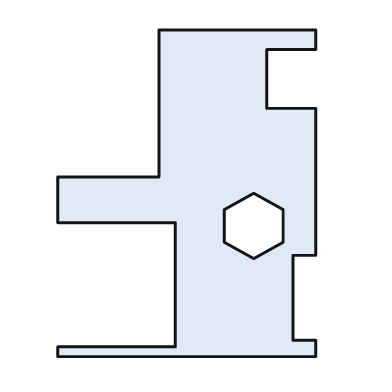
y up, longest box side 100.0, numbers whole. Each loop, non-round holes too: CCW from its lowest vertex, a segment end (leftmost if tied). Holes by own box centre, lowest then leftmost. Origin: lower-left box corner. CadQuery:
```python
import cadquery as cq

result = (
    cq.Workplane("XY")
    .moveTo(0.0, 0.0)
    .lineTo(79.0, 0.0)
    .lineTo(79.0, 5.0)
    .lineTo(72.0, 5.0)
    .lineTo(72.0, 31.0)
    .lineTo(79.0, 31.0)
    .lineTo(79.0, 76.0)
    .lineTo(64.0, 76.0)
    .lineTo(64.0, 94.0)
    .lineTo(79.0, 94.0)
    .lineTo(79.0, 100.0)
    .lineTo(31.0, 100.0)
    .lineTo(31.0, 55.0)
    .lineTo(0.0, 55.0)
    .lineTo(0.0, 41.0)
    .lineTo(36.0, 41.0)
    .lineTo(36.0, 3.0)
    .lineTo(0.0, 3.0)
    .close()
    .moveTo(60.0, 30.0)
    .lineTo(69.0, 35.0)
    .lineTo(69.0, 45.0)
    .lineTo(60.0, 50.0)
    .lineTo(51.0, 45.0)
    .lineTo(51.0, 35.0)
    .close()
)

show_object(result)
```